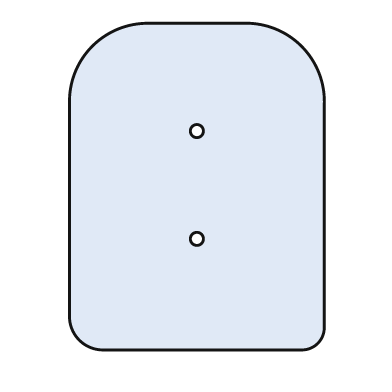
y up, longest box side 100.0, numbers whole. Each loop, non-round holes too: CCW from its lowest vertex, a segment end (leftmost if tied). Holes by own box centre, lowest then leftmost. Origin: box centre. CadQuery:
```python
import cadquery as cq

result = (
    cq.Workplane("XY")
    .moveTo(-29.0, -50.0)
    .lineTo(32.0, -50.0)
    .threePointArc((37.0, -48.0), (39.0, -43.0))
    .lineTo(39.0, 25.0)
    .threePointArc((32.0, 43.0), (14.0, 50.0))
    .lineTo(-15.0, 50.0)
    .threePointArc((-32.0, 43.0), (-39.0, 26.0))
    .lineTo(-39.0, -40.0)
    .threePointArc((-36.0, -47.0), (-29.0, -50.0))
    .close()
    .moveTo(0.0, -16.0)
    .circle(2.0)
    .moveTo(0.0, 17.0)
    .circle(2.0)
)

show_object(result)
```